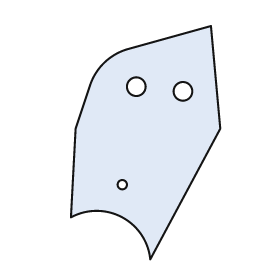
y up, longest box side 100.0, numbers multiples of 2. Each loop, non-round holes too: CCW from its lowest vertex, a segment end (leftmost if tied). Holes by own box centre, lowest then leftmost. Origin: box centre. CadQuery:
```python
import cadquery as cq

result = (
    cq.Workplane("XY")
    .moveTo(2.0, -50.0)
    .lineTo(32.0, 6.0)
    .lineTo(28.0, 50.0)
    .lineTo(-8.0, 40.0)
    .threePointArc((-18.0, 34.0), (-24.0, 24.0))
    .lineTo(-30.0, 6.0)
    .lineTo(-32.0, -32.0)
    .threePointArc((-10.0, -32.0), (2.0, -50.0))
    .close()
    .moveTo(-10.0, -18.0)
    .circle(2.0)
    .moveTo(16.0, 22.0)
    .circle(4.0)
    .moveTo(-4.0, 24.0)
    .circle(4.0)
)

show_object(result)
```